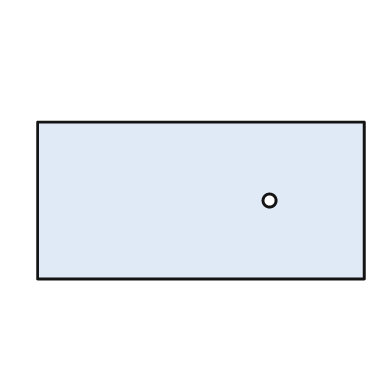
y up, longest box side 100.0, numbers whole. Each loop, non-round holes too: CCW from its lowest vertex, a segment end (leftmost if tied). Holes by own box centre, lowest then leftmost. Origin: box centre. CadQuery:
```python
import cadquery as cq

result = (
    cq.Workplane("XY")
    .moveTo(-50.0, -24.0)
    .lineTo(50.0, -24.0)
    .lineTo(50.0, 24.0)
    .lineTo(-50.0, 24.0)
    .close()
    .moveTo(21.0, 0.0)
    .circle(2.0)
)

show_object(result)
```